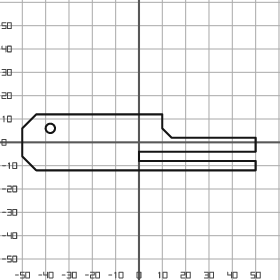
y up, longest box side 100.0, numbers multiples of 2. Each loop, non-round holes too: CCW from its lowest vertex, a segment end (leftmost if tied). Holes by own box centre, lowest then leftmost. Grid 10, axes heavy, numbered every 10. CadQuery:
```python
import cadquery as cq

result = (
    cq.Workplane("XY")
    .moveTo(-44.0, -12.0)
    .lineTo(50.0, -12.0)
    .lineTo(50.0, -8.0)
    .lineTo(0.0, -8.0)
    .lineTo(0.0, -4.0)
    .lineTo(50.0, -4.0)
    .lineTo(50.0, 2.0)
    .lineTo(14.0, 2.0)
    .lineTo(10.0, 6.0)
    .lineTo(10.0, 12.0)
    .lineTo(-44.0, 12.0)
    .lineTo(-50.0, 6.0)
    .lineTo(-50.0, -6.0)
    .close()
    .moveTo(-38.0, 6.0)
    .circle(2.0)
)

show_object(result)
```